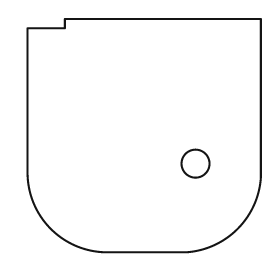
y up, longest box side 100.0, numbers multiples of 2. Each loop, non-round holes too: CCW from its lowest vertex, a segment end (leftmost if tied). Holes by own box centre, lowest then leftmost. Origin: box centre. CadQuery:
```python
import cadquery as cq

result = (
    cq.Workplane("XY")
    .moveTo(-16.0, -50.0)
    .lineTo(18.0, -50.0)
    .threePointArc((40.0, -40.0), (50.0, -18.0))
    .lineTo(50.0, 50.0)
    .lineTo(-34.0, 50.0)
    .lineTo(-34.0, 46.0)
    .lineTo(-50.0, 46.0)
    .lineTo(-50.0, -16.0)
    .threePointArc((-40.0, -40.0), (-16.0, -50.0))
    .close()
    .moveTo(22.0, -12.0)
    .circle(6.0)
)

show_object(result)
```